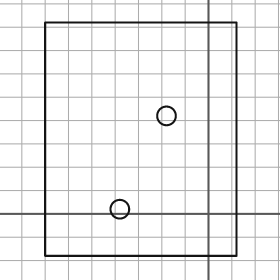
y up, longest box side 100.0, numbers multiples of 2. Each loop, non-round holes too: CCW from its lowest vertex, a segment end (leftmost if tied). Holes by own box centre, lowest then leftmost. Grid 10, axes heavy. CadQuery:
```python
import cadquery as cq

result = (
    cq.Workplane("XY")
    .moveTo(-70.0, -18.0)
    .lineTo(12.0, -18.0)
    .lineTo(12.0, 82.0)
    .lineTo(-70.0, 82.0)
    .close()
    .moveTo(-38.0, 2.0)
    .circle(4.0)
    .moveTo(-18.0, 42.0)
    .circle(4.0)
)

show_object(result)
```